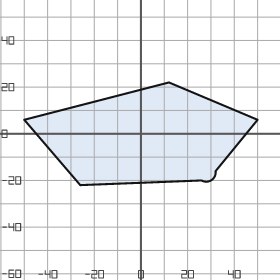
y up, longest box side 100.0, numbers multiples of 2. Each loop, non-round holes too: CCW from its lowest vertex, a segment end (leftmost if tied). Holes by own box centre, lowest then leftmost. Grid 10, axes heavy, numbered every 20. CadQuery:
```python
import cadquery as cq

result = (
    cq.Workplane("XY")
    .moveTo(-26.0, -22.0)
    .lineTo(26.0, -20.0)
    .threePointArc((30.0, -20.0), (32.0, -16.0))
    .lineTo(50.0, 6.0)
    .lineTo(12.0, 22.0)
    .lineTo(-50.0, 6.0)
    .close()
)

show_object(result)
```